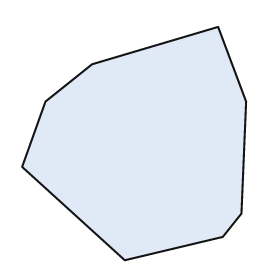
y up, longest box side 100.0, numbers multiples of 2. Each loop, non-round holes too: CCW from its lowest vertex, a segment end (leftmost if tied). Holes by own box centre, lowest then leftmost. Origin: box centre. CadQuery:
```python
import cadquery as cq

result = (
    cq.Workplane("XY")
    .moveTo(-4.0, -50.0)
    .lineTo(38.0, -40.0)
    .lineTo(46.0, -30.0)
    .lineTo(48.0, 18.0)
    .lineTo(36.0, 50.0)
    .lineTo(-18.0, 34.0)
    .lineTo(-38.0, 18.0)
    .lineTo(-48.0, -10.0)
    .close()
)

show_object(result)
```